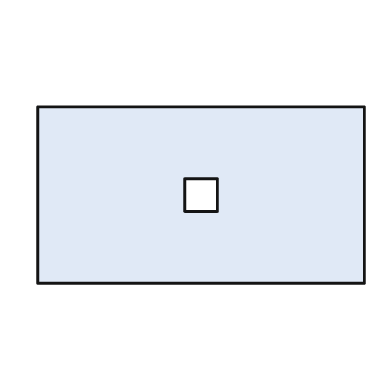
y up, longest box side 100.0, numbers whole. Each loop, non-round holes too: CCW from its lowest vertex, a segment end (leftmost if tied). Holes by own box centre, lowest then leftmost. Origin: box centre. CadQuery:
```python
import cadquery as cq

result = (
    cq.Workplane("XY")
    .moveTo(-50.0, -27.0)
    .lineTo(50.0, -27.0)
    .lineTo(50.0, 27.0)
    .lineTo(-50.0, 27.0)
    .close()
    .moveTo(-5.0, -5.0)
    .lineTo(5.0, -5.0)
    .lineTo(5.0, 5.0)
    .lineTo(-5.0, 5.0)
    .close()
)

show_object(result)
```